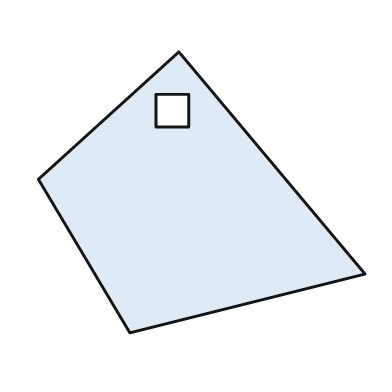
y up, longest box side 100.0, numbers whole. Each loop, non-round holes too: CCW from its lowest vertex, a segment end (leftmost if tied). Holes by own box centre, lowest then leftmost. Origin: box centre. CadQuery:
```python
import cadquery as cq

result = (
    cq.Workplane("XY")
    .moveTo(-22.0, -43.0)
    .lineTo(50.0, -25.0)
    .lineTo(-7.0, 43.0)
    .lineTo(-50.0, 4.0)
    .close()
    .moveTo(-14.0, 20.0)
    .lineTo(-4.0, 20.0)
    .lineTo(-4.0, 30.0)
    .lineTo(-14.0, 30.0)
    .close()
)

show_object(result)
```